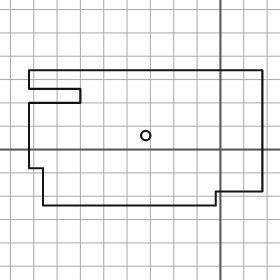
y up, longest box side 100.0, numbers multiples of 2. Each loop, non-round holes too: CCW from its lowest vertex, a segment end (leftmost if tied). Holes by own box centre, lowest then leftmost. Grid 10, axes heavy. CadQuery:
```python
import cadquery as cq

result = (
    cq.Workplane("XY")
    .moveTo(-76.0, -24.0)
    .lineTo(-2.0, -24.0)
    .lineTo(-2.0, -18.0)
    .lineTo(18.0, -18.0)
    .lineTo(18.0, 34.0)
    .lineTo(-82.0, 34.0)
    .lineTo(-82.0, 26.0)
    .lineTo(-60.0, 26.0)
    .lineTo(-60.0, 20.0)
    .lineTo(-82.0, 20.0)
    .lineTo(-82.0, -8.0)
    .lineTo(-76.0, -8.0)
    .close()
    .moveTo(-32.0, 6.0)
    .circle(2.0)
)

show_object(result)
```